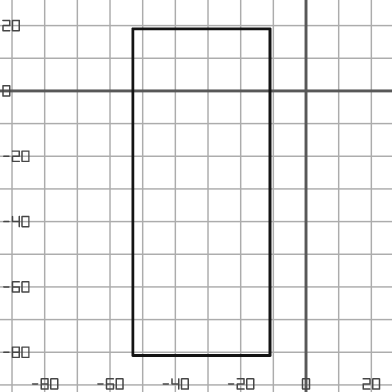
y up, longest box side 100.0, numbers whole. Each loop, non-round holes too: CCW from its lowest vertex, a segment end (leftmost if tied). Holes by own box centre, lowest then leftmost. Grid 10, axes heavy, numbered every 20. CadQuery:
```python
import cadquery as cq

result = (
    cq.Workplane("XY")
    .moveTo(-53.0, -81.0)
    .lineTo(-11.0, -81.0)
    .lineTo(-11.0, 19.0)
    .lineTo(-53.0, 19.0)
    .close()
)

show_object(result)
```